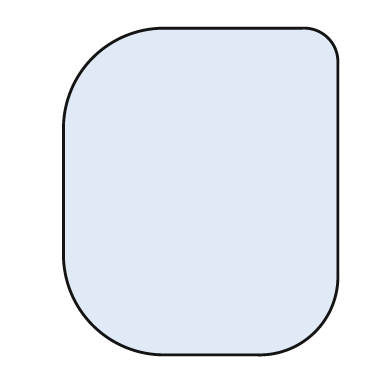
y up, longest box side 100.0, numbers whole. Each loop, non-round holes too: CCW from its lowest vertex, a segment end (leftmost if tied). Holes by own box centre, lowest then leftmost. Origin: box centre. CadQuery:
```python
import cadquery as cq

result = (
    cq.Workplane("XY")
    .moveTo(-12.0, -50.0)
    .lineTo(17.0, -50.0)
    .threePointArc((35.0, -43.0), (42.0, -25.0))
    .lineTo(42.0, 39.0)
    .threePointArc((39.0, 47.0), (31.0, 50.0))
    .lineTo(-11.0, 50.0)
    .threePointArc((-33.0, 41.0), (-42.0, 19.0))
    .lineTo(-42.0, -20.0)
    .threePointArc((-33.0, -41.0), (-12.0, -50.0))
    .close()
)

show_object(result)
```